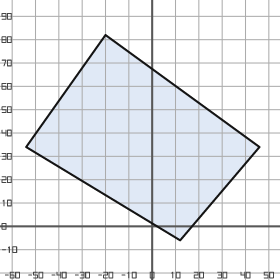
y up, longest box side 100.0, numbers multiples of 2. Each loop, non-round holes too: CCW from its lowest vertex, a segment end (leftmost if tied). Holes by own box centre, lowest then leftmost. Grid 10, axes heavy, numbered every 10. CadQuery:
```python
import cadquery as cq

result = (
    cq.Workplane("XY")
    .moveTo(12.0, -6.0)
    .lineTo(46.0, 34.0)
    .lineTo(-20.0, 82.0)
    .lineTo(-54.0, 34.0)
    .close()
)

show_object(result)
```